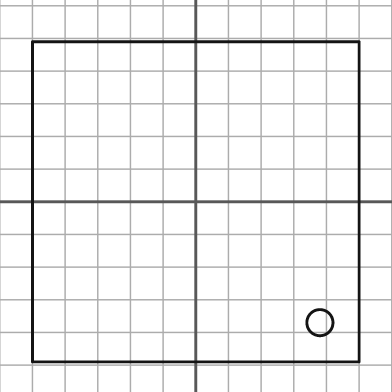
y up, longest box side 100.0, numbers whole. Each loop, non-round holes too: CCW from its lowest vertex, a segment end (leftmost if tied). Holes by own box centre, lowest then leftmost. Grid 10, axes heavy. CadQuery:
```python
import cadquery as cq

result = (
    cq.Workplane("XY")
    .moveTo(-50.0, -49.0)
    .lineTo(50.0, -49.0)
    .lineTo(50.0, 49.0)
    .lineTo(-50.0, 49.0)
    .close()
    .moveTo(38.0, -37.0)
    .circle(4.0)
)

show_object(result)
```